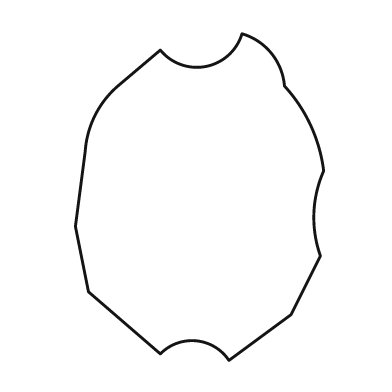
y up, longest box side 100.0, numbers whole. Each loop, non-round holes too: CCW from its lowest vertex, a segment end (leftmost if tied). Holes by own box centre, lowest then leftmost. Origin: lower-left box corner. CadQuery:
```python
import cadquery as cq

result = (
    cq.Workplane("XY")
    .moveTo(47.0, 0.0)
    .lineTo(66.0, 14.0)
    .lineTo(75.0, 32.0)
    .threePointArc((73.0, 45.0), (76.0, 58.0))
    .threePointArc((72.0, 72.0), (64.0, 84.0))
    .threePointArc((60.0, 94.0), (51.0, 100.0))
    .threePointArc((40.0, 90.0), (26.0, 95.0))
    .lineTo(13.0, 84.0)
    .threePointArc((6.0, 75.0), (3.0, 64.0))
    .lineTo(0.0, 41.0)
    .lineTo(4.0, 21.0)
    .lineTo(26.0, 2.0)
    .threePointArc((37.0, 6.0), (47.0, 0.0))
    .close()
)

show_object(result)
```